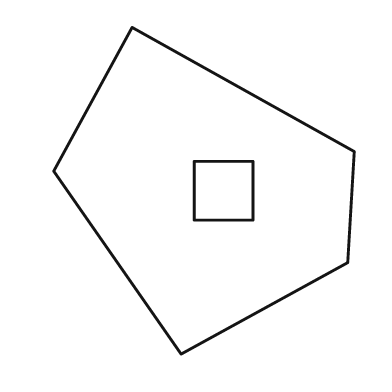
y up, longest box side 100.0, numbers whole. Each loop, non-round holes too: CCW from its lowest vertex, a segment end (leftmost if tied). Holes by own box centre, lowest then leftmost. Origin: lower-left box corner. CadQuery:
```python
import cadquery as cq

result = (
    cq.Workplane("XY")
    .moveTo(39.0, 0.0)
    .lineTo(90.0, 28.0)
    .lineTo(92.0, 62.0)
    .lineTo(24.0, 100.0)
    .lineTo(0.0, 56.0)
    .close()
    .moveTo(43.0, 41.0)
    .lineTo(61.0, 41.0)
    .lineTo(61.0, 59.0)
    .lineTo(43.0, 59.0)
    .close()
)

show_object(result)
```